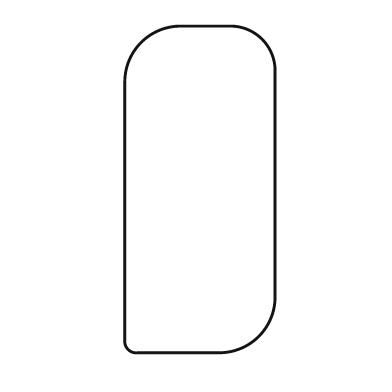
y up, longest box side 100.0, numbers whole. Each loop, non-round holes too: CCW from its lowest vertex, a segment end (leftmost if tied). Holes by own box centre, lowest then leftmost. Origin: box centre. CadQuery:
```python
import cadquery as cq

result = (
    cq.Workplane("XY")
    .moveTo(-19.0, -50.0)
    .lineTo(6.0, -50.0)
    .threePointArc((18.0, -45.0), (23.0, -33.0))
    .lineTo(23.0, 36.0)
    .threePointArc((19.0, 46.0), (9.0, 50.0))
    .lineTo(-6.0, 50.0)
    .threePointArc((-18.0, 45.0), (-23.0, 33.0))
    .lineTo(-23.0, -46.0)
    .threePointArc((-22.0, -49.0), (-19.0, -50.0))
    .close()
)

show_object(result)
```